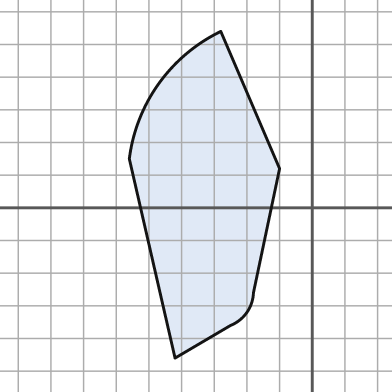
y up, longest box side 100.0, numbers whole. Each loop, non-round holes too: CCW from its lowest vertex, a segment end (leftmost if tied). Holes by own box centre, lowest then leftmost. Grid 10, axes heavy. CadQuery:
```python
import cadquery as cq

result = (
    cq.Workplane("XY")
    .moveTo(-42.0, -46.0)
    .lineTo(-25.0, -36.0)
    .threePointArc((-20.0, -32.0), (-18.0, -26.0))
    .lineTo(-10.0, 12.0)
    .lineTo(-28.0, 54.0)
    .threePointArc((-47.0, 38.0), (-56.0, 15.0))
    .close()
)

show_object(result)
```